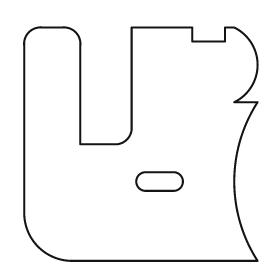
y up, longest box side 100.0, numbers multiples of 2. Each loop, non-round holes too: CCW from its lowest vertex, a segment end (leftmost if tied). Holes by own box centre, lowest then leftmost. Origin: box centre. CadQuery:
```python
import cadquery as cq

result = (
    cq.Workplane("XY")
    .moveTo(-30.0, -50.0)
    .lineTo(50.0, -50.0)
    .threePointArc((40.0, -16.0), (50.0, 18.0))
    .lineTo(40.0, 18.0)
    .threePointArc((50.0, 34.0), (40.0, 50.0))
    .lineTo(36.0, 50.0)
    .lineTo(36.0, 44.0)
    .lineTo(22.0, 44.0)
    .lineTo(22.0, 50.0)
    .lineTo(-4.0, 50.0)
    .lineTo(-4.0, 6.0)
    .threePointArc((-6.0, 2.0), (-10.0, 0.0))
    .lineTo(-26.0, 0.0)
    .lineTo(-26.0, 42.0)
    .threePointArc((-28.0, 48.0), (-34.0, 50.0))
    .lineTo(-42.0, 50.0)
    .threePointArc((-48.0, 48.0), (-50.0, 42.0))
    .lineTo(-50.0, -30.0)
    .threePointArc((-44.0, -44.0), (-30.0, -50.0))
    .close()
    .moveTo(2.0, -20.0)
    .lineTo(14.0, -20.0)
    .threePointArc((18.0, -16.0), (14.0, -12.0))
    .lineTo(2.0, -12.0)
    .threePointArc((-2.0, -16.0), (2.0, -20.0))
    .close()
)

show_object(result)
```